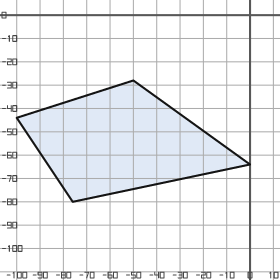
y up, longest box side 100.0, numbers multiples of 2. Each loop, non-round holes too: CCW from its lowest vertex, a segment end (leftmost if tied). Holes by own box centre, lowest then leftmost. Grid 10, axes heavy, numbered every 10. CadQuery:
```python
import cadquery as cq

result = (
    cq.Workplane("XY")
    .moveTo(-76.0, -80.0)
    .lineTo(0.0, -64.0)
    .lineTo(-50.0, -28.0)
    .lineTo(-100.0, -44.0)
    .close()
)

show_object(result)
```